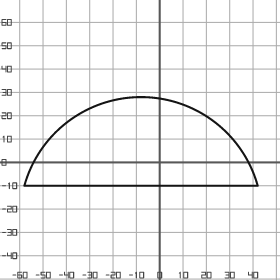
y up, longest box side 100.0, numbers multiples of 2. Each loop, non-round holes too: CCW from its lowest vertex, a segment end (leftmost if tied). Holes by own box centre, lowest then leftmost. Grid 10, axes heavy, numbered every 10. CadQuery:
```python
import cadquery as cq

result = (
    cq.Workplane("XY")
    .moveTo(-58.0, -10.0)
    .lineTo(42.0, -10.0)
    .threePointArc((-8.0, 28.0), (-58.0, -10.0))
    .close()
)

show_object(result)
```